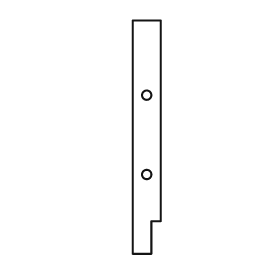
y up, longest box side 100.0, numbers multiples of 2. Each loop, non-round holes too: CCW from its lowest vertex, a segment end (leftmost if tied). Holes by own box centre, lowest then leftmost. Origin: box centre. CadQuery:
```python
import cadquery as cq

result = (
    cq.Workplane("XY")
    .moveTo(-6.0, -50.0)
    .lineTo(2.0, -50.0)
    .lineTo(2.0, -36.0)
    .lineTo(6.0, -36.0)
    .lineTo(6.0, 50.0)
    .lineTo(-6.0, 50.0)
    .close()
    .moveTo(0.0, -16.0)
    .circle(2.0)
    .moveTo(0.0, 18.0)
    .circle(2.0)
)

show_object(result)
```